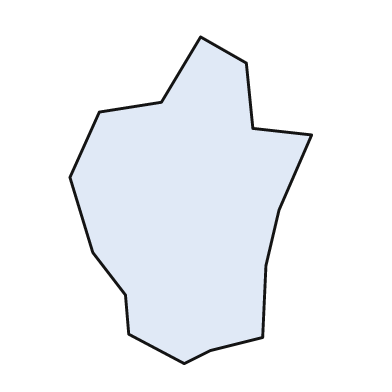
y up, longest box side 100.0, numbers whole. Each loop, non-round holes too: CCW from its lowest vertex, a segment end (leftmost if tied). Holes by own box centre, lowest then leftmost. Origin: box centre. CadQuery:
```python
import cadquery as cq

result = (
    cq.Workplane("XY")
    .moveTo(-2.0, -50.0)
    .lineTo(6.0, -46.0)
    .lineTo(22.0, -42.0)
    .lineTo(23.0, -20.0)
    .lineTo(27.0, -3.0)
    .lineTo(37.0, 20.0)
    .lineTo(19.0, 22.0)
    .lineTo(17.0, 42.0)
    .lineTo(3.0, 50.0)
    .lineTo(-9.0, 30.0)
    .lineTo(-28.0, 27.0)
    .lineTo(-37.0, 7.0)
    .lineTo(-30.0, -16.0)
    .lineTo(-20.0, -29.0)
    .lineTo(-19.0, -41.0)
    .close()
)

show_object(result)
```